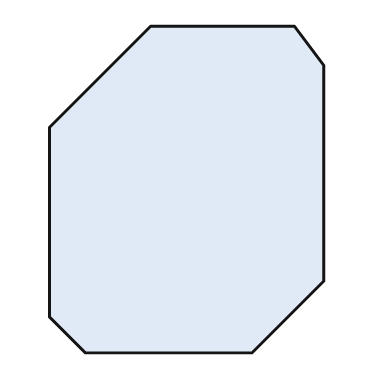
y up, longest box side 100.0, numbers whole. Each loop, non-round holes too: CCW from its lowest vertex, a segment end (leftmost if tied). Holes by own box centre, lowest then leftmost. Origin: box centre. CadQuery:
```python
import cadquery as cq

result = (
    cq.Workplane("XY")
    .moveTo(-31.0, -50.0)
    .lineTo(20.0, -50.0)
    .lineTo(42.0, -28.0)
    .lineTo(42.0, 38.0)
    .lineTo(33.0, 50.0)
    .lineTo(-11.0, 50.0)
    .lineTo(-42.0, 19.0)
    .lineTo(-42.0, -39.0)
    .close()
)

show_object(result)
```